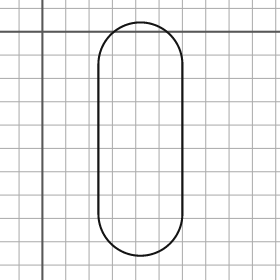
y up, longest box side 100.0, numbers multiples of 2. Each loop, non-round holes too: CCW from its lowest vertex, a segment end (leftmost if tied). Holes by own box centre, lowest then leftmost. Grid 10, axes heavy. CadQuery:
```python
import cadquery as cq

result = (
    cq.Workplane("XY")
    .moveTo(24.0, -78.0)
    .threePointArc((42.0, -96.0), (60.0, -78.0))
    .lineTo(60.0, -14.0)
    .threePointArc((42.0, 4.0), (24.0, -14.0))
    .close()
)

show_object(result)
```